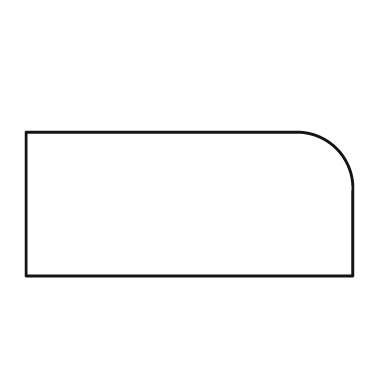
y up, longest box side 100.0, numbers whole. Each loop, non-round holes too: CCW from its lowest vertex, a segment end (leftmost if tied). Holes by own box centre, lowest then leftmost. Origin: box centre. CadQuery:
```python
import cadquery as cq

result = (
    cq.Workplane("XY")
    .moveTo(-50.0, -22.0)
    .lineTo(50.0, -22.0)
    .lineTo(50.0, 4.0)
    .threePointArc((45.0, 17.0), (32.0, 22.0))
    .lineTo(-50.0, 22.0)
    .close()
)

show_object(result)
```